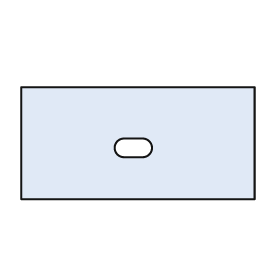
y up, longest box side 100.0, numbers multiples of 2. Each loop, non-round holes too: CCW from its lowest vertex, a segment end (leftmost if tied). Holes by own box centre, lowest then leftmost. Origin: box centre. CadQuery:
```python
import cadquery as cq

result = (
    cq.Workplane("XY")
    .moveTo(-50.0, -24.0)
    .lineTo(50.0, -24.0)
    .lineTo(50.0, 24.0)
    .lineTo(-50.0, 24.0)
    .close()
    .moveTo(-6.0, -6.0)
    .lineTo(2.0, -6.0)
    .threePointArc((6.0, -2.0), (2.0, 2.0))
    .lineTo(-6.0, 2.0)
    .threePointArc((-10.0, -2.0), (-6.0, -6.0))
    .close()
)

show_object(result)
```